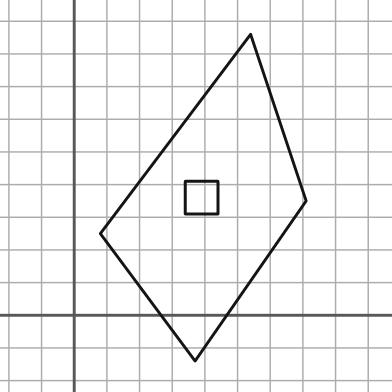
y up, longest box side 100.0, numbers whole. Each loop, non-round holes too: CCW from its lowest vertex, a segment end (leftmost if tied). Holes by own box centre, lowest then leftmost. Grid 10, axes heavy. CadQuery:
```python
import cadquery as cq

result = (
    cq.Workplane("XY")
    .moveTo(37.0, -14.0)
    .lineTo(71.0, 35.0)
    .lineTo(54.0, 86.0)
    .lineTo(8.0, 25.0)
    .close()
    .moveTo(34.0, 31.0)
    .lineTo(44.0, 31.0)
    .lineTo(44.0, 41.0)
    .lineTo(34.0, 41.0)
    .close()
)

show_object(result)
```